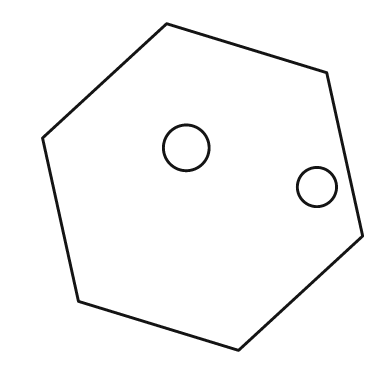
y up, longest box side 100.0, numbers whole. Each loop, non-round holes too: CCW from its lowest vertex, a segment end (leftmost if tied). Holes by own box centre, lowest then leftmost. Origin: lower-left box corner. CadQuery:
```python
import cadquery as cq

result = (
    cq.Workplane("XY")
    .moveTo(60.0, 0.0)
    .lineTo(98.0, 35.0)
    .lineTo(87.0, 85.0)
    .lineTo(38.0, 100.0)
    .lineTo(0.0, 65.0)
    .lineTo(11.0, 15.0)
    .close()
    .moveTo(84.0, 50.0)
    .circle(6.0)
    .moveTo(44.0, 62.0)
    .circle(7.0)
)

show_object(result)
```